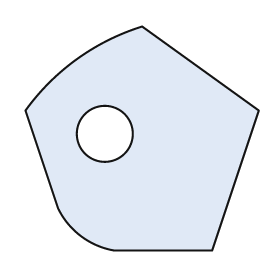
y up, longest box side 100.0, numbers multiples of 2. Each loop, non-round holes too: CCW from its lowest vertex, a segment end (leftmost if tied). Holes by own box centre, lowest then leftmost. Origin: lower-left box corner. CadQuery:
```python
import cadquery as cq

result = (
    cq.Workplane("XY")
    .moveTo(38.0, 0.0)
    .lineTo(80.0, 0.0)
    .lineTo(100.0, 60.0)
    .lineTo(50.0, 96.0)
    .threePointArc((22.0, 82.0), (0.0, 60.0))
    .lineTo(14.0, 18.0)
    .threePointArc((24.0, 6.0), (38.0, 0.0))
    .close()
    .moveTo(34.0, 50.0)
    .circle(12.0)
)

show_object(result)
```